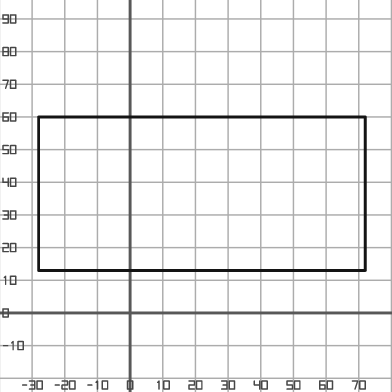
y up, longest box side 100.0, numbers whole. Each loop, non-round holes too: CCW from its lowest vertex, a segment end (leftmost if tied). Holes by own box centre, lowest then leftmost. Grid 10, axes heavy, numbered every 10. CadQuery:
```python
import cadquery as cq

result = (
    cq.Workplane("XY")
    .moveTo(-28.0, 13.0)
    .lineTo(72.0, 13.0)
    .lineTo(72.0, 60.0)
    .lineTo(-28.0, 60.0)
    .close()
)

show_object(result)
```